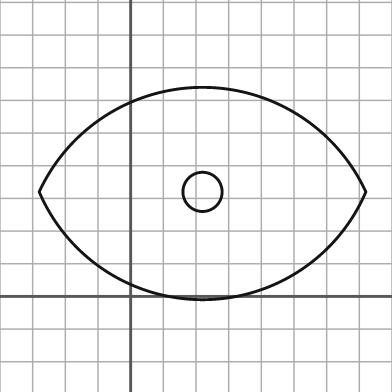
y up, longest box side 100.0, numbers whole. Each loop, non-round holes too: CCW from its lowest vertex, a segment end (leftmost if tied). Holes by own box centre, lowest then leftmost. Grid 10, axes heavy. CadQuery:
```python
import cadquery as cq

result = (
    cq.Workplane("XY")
    .moveTo(-28.0, 32.0)
    .threePointArc((22.0, -1.0), (72.0, 32.0))
    .threePointArc((22.0, 64.0), (-28.0, 32.0))
    .close()
    .moveTo(22.0, 32.0)
    .circle(6.0)
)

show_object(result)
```